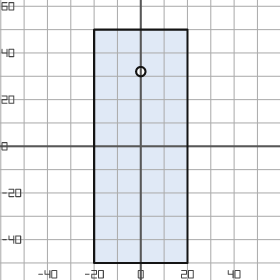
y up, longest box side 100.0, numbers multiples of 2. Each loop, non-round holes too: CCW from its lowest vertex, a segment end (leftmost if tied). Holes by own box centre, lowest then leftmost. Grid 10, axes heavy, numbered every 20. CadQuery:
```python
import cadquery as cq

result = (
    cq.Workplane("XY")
    .moveTo(-20.0, -50.0)
    .lineTo(20.0, -50.0)
    .lineTo(20.0, 50.0)
    .lineTo(-20.0, 50.0)
    .close()
    .moveTo(0.0, 32.0)
    .circle(2.0)
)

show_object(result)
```